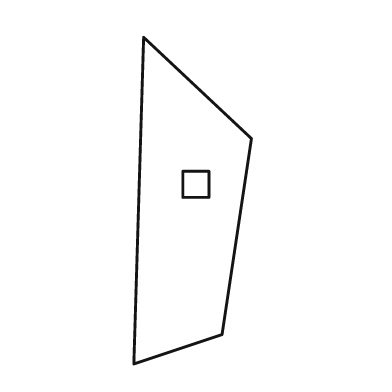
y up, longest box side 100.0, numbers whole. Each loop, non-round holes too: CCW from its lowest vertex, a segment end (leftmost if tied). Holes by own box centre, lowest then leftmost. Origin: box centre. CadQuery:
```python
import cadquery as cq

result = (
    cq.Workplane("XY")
    .moveTo(-18.0, -50.0)
    .lineTo(9.0, -41.0)
    .lineTo(18.0, 19.0)
    .lineTo(-15.0, 50.0)
    .close()
    .moveTo(-3.0, 1.0)
    .lineTo(5.0, 1.0)
    .lineTo(5.0, 9.0)
    .lineTo(-3.0, 9.0)
    .close()
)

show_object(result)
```